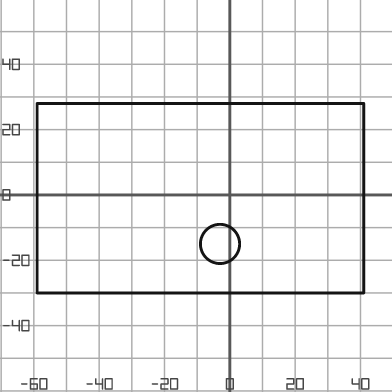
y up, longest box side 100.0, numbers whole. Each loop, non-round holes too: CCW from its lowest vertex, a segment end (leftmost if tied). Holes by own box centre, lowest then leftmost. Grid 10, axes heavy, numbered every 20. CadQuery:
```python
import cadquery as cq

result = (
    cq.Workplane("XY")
    .moveTo(-59.0, -30.0)
    .lineTo(41.0, -30.0)
    .lineTo(41.0, 28.0)
    .lineTo(-59.0, 28.0)
    .close()
    .moveTo(-3.0, -15.0)
    .circle(6.0)
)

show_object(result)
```